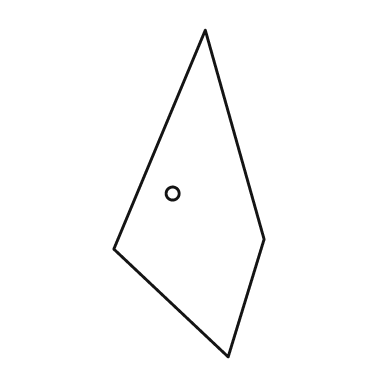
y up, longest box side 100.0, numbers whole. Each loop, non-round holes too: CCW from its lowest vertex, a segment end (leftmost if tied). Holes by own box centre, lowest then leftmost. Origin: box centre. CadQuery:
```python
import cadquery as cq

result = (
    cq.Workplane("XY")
    .moveTo(12.0, -50.0)
    .lineTo(23.0, -14.0)
    .lineTo(5.0, 50.0)
    .lineTo(-23.0, -17.0)
    .close()
    .moveTo(-5.0, 0.0)
    .circle(2.0)
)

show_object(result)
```